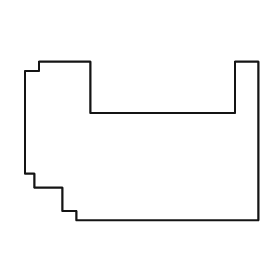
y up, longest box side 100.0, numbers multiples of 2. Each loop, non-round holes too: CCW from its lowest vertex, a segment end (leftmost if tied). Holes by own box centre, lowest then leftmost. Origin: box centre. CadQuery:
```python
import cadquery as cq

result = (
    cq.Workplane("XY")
    .moveTo(-28.0, -34.0)
    .lineTo(50.0, -34.0)
    .lineTo(50.0, 34.0)
    .lineTo(40.0, 34.0)
    .lineTo(40.0, 12.0)
    .lineTo(-22.0, 12.0)
    .lineTo(-22.0, 34.0)
    .lineTo(-44.0, 34.0)
    .lineTo(-44.0, 30.0)
    .lineTo(-50.0, 30.0)
    .lineTo(-50.0, -14.0)
    .lineTo(-46.0, -14.0)
    .lineTo(-46.0, -20.0)
    .lineTo(-34.0, -20.0)
    .lineTo(-34.0, -30.0)
    .lineTo(-28.0, -30.0)
    .close()
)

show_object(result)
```